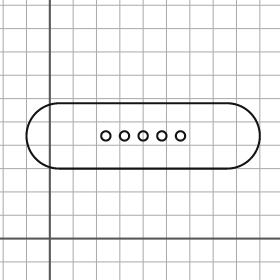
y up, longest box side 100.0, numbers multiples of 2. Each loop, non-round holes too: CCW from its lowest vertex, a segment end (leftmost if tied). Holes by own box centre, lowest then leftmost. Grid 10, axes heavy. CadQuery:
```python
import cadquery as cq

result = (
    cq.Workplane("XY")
    .moveTo(4.0, 30.0)
    .lineTo(76.0, 30.0)
    .threePointArc((90.0, 44.0), (76.0, 58.0))
    .lineTo(4.0, 58.0)
    .threePointArc((-10.0, 44.0), (4.0, 30.0))
    .close()
    .moveTo(24.0, 44.0)
    .circle(2.0)
    .moveTo(32.0, 44.0)
    .circle(2.0)
    .moveTo(40.0, 44.0)
    .circle(2.0)
    .moveTo(48.0, 44.0)
    .circle(2.0)
    .moveTo(56.0, 44.0)
    .circle(2.0)
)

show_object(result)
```